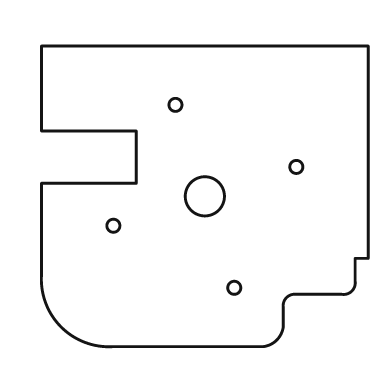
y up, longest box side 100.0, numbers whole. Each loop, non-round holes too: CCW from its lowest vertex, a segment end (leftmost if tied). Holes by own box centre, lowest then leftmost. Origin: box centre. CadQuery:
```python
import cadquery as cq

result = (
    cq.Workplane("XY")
    .moveTo(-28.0, -46.0)
    .lineTo(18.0, -46.0)
    .threePointArc((22.0, -44.0), (24.0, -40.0))
    .lineTo(24.0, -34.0)
    .threePointArc((25.0, -31.0), (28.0, -30.0))
    .lineTo(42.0, -30.0)
    .threePointArc((45.0, -29.0), (46.0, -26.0))
    .lineTo(46.0, -19.0)
    .lineTo(50.0, -19.0)
    .lineTo(50.0, 46.0)
    .lineTo(-50.0, 46.0)
    .lineTo(-50.0, 20.0)
    .lineTo(-21.0, 20.0)
    .lineTo(-21.0, 4.0)
    .lineTo(-50.0, 4.0)
    .lineTo(-50.0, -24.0)
    .threePointArc((-44.0, -40.0), (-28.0, -46.0))
    .close()
    .moveTo(9.0, -28.0)
    .circle(2.0)
    .moveTo(-28.0, -9.0)
    .circle(2.0)
    .moveTo(0.0, 0.0)
    .circle(6.0)
    .moveTo(28.0, 9.0)
    .circle(2.0)
    .moveTo(-9.0, 28.0)
    .circle(2.0)
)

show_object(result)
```